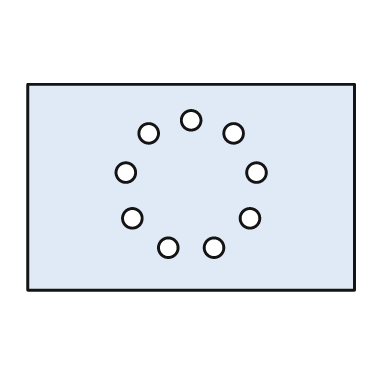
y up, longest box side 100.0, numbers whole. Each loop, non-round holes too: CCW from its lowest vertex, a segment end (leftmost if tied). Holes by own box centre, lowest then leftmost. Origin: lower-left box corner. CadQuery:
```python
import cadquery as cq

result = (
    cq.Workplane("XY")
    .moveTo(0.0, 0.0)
    .lineTo(100.0, 0.0)
    .lineTo(100.0, 63.0)
    .lineTo(0.0, 63.0)
    .close()
    .moveTo(43.0, 13.0)
    .circle(3.0)
    .moveTo(57.0, 13.0)
    .circle(3.0)
    .moveTo(32.0, 22.0)
    .circle(3.0)
    .moveTo(68.0, 22.0)
    .circle(3.0)
    .moveTo(30.0, 36.0)
    .circle(3.0)
    .moveTo(70.0, 36.0)
    .circle(3.0)
    .moveTo(37.0, 48.0)
    .circle(3.0)
    .moveTo(63.0, 48.0)
    .circle(3.0)
    .moveTo(50.0, 52.0)
    .circle(3.0)
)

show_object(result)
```